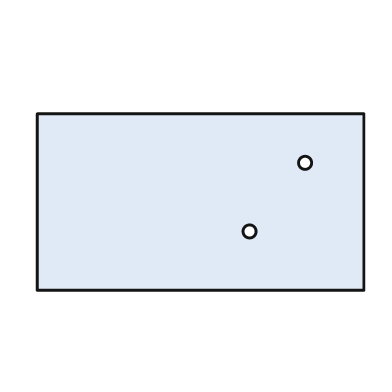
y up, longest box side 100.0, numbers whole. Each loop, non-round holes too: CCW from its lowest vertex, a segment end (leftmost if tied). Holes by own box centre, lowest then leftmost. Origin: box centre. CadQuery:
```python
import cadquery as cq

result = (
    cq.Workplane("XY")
    .moveTo(-50.0, -27.0)
    .lineTo(50.0, -27.0)
    .lineTo(50.0, 27.0)
    .lineTo(-50.0, 27.0)
    .close()
    .moveTo(15.0, -9.0)
    .circle(2.0)
    .moveTo(32.0, 12.0)
    .circle(2.0)
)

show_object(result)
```